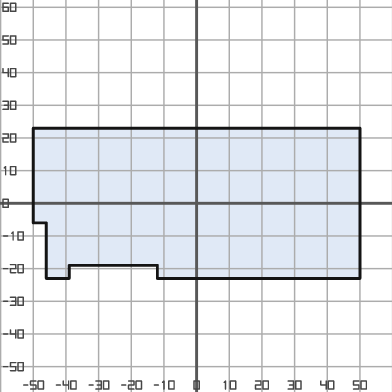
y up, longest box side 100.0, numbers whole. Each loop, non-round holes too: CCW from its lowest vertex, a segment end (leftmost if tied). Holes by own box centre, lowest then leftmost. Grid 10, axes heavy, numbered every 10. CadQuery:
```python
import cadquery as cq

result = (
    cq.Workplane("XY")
    .moveTo(-46.0, -23.0)
    .lineTo(-39.0, -23.0)
    .lineTo(-39.0, -19.0)
    .lineTo(-12.0, -19.0)
    .lineTo(-12.0, -23.0)
    .lineTo(50.0, -23.0)
    .lineTo(50.0, 23.0)
    .lineTo(-50.0, 23.0)
    .lineTo(-50.0, -6.0)
    .lineTo(-46.0, -6.0)
    .close()
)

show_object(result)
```